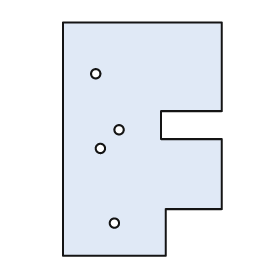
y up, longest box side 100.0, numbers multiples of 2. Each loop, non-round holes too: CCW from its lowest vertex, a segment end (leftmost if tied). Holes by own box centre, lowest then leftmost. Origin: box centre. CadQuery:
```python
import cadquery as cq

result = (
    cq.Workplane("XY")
    .moveTo(-34.0, -50.0)
    .lineTo(10.0, -50.0)
    .lineTo(10.0, -30.0)
    .lineTo(34.0, -30.0)
    .lineTo(34.0, 0.0)
    .lineTo(8.0, 0.0)
    .lineTo(8.0, 12.0)
    .lineTo(34.0, 12.0)
    .lineTo(34.0, 50.0)
    .lineTo(-34.0, 50.0)
    .close()
    .moveTo(-12.0, -36.0)
    .circle(2.0)
    .moveTo(-18.0, -4.0)
    .circle(2.0)
    .moveTo(-10.0, 4.0)
    .circle(2.0)
    .moveTo(-20.0, 28.0)
    .circle(2.0)
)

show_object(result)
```